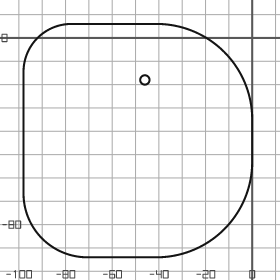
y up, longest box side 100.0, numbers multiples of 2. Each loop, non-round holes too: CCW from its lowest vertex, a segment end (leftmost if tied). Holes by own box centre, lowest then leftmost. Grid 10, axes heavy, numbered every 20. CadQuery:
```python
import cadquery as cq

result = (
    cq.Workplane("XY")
    .moveTo(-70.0, -94.0)
    .lineTo(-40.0, -94.0)
    .threePointArc((-12.0, -82.0), (0.0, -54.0))
    .lineTo(0.0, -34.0)
    .threePointArc((-12.0, -6.0), (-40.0, 6.0))
    .lineTo(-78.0, 6.0)
    .threePointArc((-92.0, 0.0), (-98.0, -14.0))
    .lineTo(-98.0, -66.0)
    .threePointArc((-90.0, -86.0), (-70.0, -94.0))
    .close()
    .moveTo(-46.0, -18.0)
    .circle(2.0)
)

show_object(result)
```